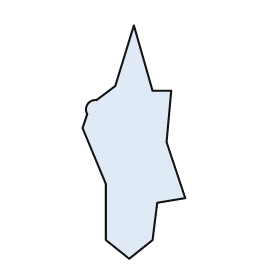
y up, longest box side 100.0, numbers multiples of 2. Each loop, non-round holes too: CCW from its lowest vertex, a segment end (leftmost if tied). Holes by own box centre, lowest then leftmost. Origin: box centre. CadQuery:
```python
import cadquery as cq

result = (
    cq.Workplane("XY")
    .moveTo(-2.0, -50.0)
    .lineTo(8.0, -42.0)
    .lineTo(10.0, -26.0)
    .lineTo(22.0, -24.0)
    .lineTo(14.0, 0.0)
    .lineTo(16.0, 22.0)
    .lineTo(8.0, 22.0)
    .lineTo(0.0, 50.0)
    .lineTo(-8.0, 24.0)
    .lineTo(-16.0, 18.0)
    .threePointArc((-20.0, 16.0), (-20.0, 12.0))
    .lineTo(-22.0, 6.0)
    .lineTo(-12.0, -18.0)
    .lineTo(-12.0, -42.0)
    .close()
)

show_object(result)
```